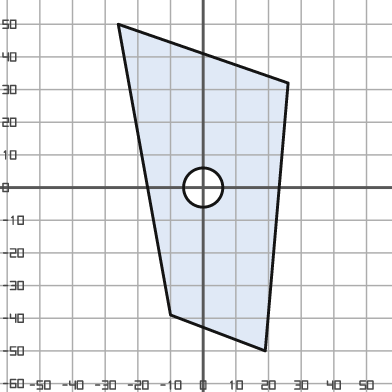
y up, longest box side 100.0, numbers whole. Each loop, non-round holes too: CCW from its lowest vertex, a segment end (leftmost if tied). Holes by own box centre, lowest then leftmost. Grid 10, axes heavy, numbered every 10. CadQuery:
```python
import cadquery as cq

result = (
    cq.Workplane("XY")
    .moveTo(19.0, -50.0)
    .lineTo(26.0, 32.0)
    .lineTo(-26.0, 50.0)
    .lineTo(-10.0, -39.0)
    .close()
    .moveTo(0.0, 0.0)
    .circle(6.0)
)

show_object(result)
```